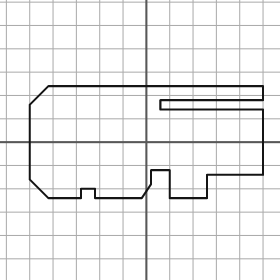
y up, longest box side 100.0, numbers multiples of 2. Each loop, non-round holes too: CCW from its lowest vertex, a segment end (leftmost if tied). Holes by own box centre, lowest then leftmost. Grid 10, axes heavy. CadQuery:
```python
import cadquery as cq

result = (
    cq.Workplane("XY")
    .moveTo(-42.0, -24.0)
    .lineTo(-28.0, -24.0)
    .lineTo(-28.0, -20.0)
    .lineTo(-22.0, -20.0)
    .lineTo(-22.0, -24.0)
    .lineTo(-2.0, -24.0)
    .lineTo(2.0, -18.0)
    .lineTo(2.0, -12.0)
    .lineTo(10.0, -12.0)
    .lineTo(10.0, -24.0)
    .lineTo(26.0, -24.0)
    .lineTo(26.0, -14.0)
    .lineTo(50.0, -14.0)
    .lineTo(50.0, 14.0)
    .lineTo(6.0, 14.0)
    .lineTo(6.0, 18.0)
    .lineTo(50.0, 18.0)
    .lineTo(50.0, 24.0)
    .lineTo(-42.0, 24.0)
    .lineTo(-50.0, 16.0)
    .lineTo(-50.0, -16.0)
    .close()
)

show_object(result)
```